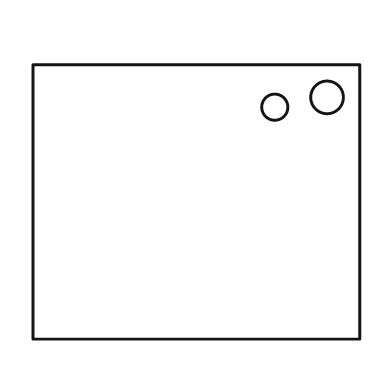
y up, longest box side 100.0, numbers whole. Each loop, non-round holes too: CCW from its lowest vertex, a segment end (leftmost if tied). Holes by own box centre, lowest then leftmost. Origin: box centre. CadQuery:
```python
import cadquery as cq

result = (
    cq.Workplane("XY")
    .moveTo(-50.0, -42.0)
    .lineTo(50.0, -42.0)
    .lineTo(50.0, 42.0)
    .lineTo(-50.0, 42.0)
    .close()
    .moveTo(24.0, 29.0)
    .circle(4.0)
    .moveTo(40.0, 32.0)
    .circle(5.0)
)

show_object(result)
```